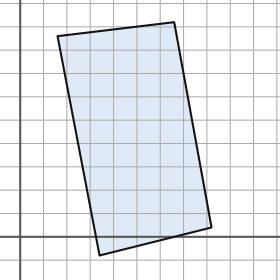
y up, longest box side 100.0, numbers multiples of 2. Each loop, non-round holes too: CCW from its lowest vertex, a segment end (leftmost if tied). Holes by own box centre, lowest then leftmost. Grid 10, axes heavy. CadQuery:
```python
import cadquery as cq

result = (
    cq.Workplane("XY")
    .moveTo(34.0, -8.0)
    .lineTo(82.0, 4.0)
    .lineTo(66.0, 92.0)
    .lineTo(16.0, 86.0)
    .close()
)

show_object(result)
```